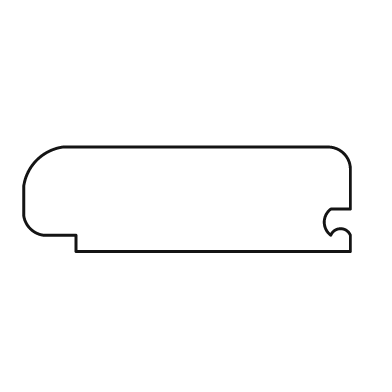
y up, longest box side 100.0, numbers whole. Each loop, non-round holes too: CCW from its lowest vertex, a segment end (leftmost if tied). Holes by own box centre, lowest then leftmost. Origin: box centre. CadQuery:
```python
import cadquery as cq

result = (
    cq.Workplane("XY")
    .moveTo(-34.0, -16.0)
    .lineTo(50.0, -16.0)
    .lineTo(50.0, -11.0)
    .threePointArc((47.0, -9.0), (44.0, -11.0))
    .threePointArc((42.0, -7.0), (44.0, -3.0))
    .lineTo(50.0, -3.0)
    .lineTo(50.0, 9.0)
    .threePointArc((48.0, 14.0), (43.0, 16.0))
    .lineTo(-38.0, 16.0)
    .threePointArc((-46.0, 12.0), (-50.0, 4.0))
    .lineTo(-50.0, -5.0)
    .threePointArc((-48.0, -9.0), (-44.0, -11.0))
    .lineTo(-34.0, -11.0)
    .close()
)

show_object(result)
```